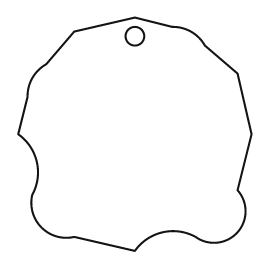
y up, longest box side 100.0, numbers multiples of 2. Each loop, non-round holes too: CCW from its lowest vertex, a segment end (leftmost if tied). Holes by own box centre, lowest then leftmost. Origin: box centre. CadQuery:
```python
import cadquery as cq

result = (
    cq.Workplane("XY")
    .moveTo(0.0, -50.0)
    .threePointArc((12.0, -42.0), (26.0, -44.0))
    .threePointArc((44.0, -42.0), (44.0, -24.0))
    .lineTo(50.0, 0.0)
    .lineTo(44.0, 26.0)
    .lineTo(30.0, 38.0)
    .threePointArc((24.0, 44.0), (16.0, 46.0))
    .lineTo(0.0, 50.0)
    .lineTo(-26.0, 44.0)
    .lineTo(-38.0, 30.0)
    .threePointArc((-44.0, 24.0), (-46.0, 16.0))
    .lineTo(-50.0, 0.0)
    .threePointArc((-42.0, -12.0), (-44.0, -26.0))
    .threePointArc((-40.0, -40.0), (-26.0, -44.0))
    .close()
    .moveTo(0.0, 42.0)
    .circle(4.0)
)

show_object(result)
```